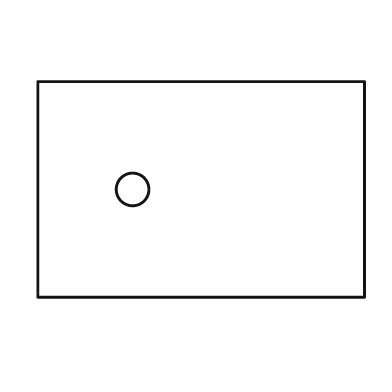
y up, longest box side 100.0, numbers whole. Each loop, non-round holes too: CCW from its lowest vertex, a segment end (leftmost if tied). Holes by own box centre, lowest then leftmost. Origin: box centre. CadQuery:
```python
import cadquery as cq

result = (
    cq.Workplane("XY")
    .moveTo(-50.0, -33.0)
    .lineTo(50.0, -33.0)
    .lineTo(50.0, 33.0)
    .lineTo(-50.0, 33.0)
    .close()
    .moveTo(-21.0, 0.0)
    .circle(5.0)
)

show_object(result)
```